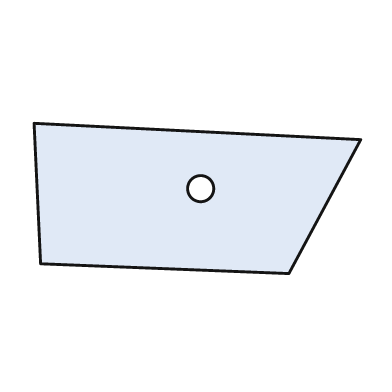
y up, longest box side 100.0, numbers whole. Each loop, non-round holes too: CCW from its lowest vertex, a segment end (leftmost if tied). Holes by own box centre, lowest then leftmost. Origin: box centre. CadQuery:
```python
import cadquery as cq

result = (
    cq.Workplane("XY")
    .moveTo(28.0, -23.0)
    .lineTo(50.0, 18.0)
    .lineTo(-50.0, 23.0)
    .lineTo(-48.0, -20.0)
    .close()
    .moveTo(1.0, 3.0)
    .circle(4.0)
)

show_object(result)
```